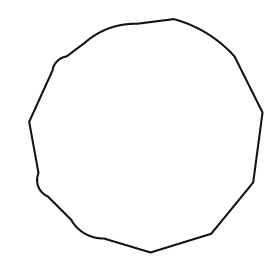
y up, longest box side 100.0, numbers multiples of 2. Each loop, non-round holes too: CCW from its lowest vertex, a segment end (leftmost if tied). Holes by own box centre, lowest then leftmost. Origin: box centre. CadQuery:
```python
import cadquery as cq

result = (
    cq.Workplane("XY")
    .moveTo(2.0, -50.0)
    .lineTo(28.0, -42.0)
    .lineTo(46.0, -20.0)
    .lineTo(50.0, 10.0)
    .lineTo(38.0, 34.0)
    .threePointArc((26.0, 44.0), (12.0, 50.0))
    .lineTo(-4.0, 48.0)
    .threePointArc((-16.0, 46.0), (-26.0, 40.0))
    .lineTo(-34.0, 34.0)
    .threePointArc((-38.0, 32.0), (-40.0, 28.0))
    .lineTo(-50.0, 6.0)
    .lineTo(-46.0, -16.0)
    .threePointArc((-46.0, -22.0), (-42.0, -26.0))
    .lineTo(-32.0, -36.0)
    .threePointArc((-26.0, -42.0), (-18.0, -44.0))
    .close()
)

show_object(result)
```